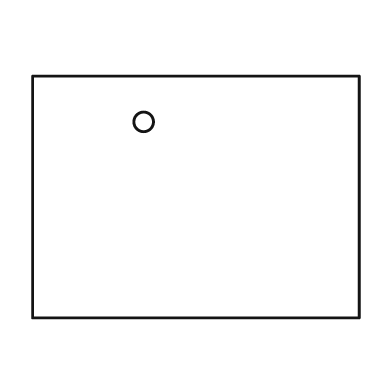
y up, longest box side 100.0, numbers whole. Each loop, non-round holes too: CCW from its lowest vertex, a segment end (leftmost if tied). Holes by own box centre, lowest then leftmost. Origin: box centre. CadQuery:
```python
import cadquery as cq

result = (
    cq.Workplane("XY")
    .moveTo(-50.0, -37.0)
    .lineTo(50.0, -37.0)
    .lineTo(50.0, 37.0)
    .lineTo(-50.0, 37.0)
    .close()
    .moveTo(-16.0, 23.0)
    .circle(3.0)
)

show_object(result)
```